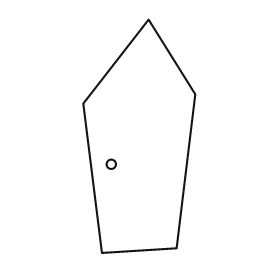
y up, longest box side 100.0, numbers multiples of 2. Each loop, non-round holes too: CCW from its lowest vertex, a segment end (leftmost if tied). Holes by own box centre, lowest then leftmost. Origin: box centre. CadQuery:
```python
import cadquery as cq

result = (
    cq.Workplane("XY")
    .moveTo(-16.0, -50.0)
    .lineTo(16.0, -48.0)
    .lineTo(24.0, 18.0)
    .lineTo(4.0, 50.0)
    .lineTo(-24.0, 14.0)
    .close()
    .moveTo(-12.0, -12.0)
    .circle(2.0)
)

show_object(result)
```